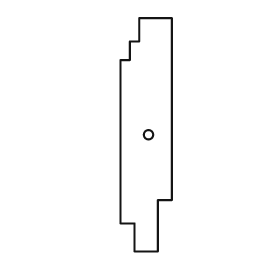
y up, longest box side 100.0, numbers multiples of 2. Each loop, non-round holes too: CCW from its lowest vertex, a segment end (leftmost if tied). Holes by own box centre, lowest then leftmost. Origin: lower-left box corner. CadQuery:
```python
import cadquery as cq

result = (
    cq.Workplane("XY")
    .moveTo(6.0, 0.0)
    .lineTo(16.0, 0.0)
    .lineTo(16.0, 22.0)
    .lineTo(22.0, 22.0)
    .lineTo(22.0, 100.0)
    .lineTo(8.0, 100.0)
    .lineTo(8.0, 90.0)
    .lineTo(4.0, 90.0)
    .lineTo(4.0, 82.0)
    .lineTo(0.0, 82.0)
    .lineTo(0.0, 12.0)
    .lineTo(6.0, 12.0)
    .close()
    .moveTo(12.0, 50.0)
    .circle(2.0)
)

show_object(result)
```